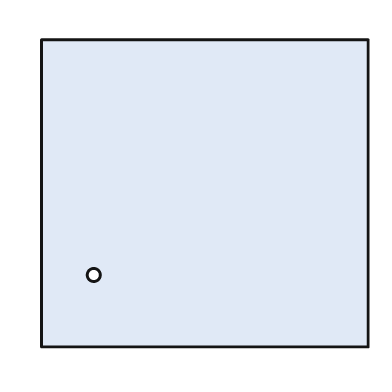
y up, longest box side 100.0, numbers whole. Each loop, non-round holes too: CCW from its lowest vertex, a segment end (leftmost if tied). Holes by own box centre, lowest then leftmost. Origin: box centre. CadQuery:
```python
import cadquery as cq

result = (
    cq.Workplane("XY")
    .moveTo(-50.0, -47.0)
    .lineTo(50.0, -47.0)
    .lineTo(50.0, 47.0)
    .lineTo(-50.0, 47.0)
    .close()
    .moveTo(-34.0, -25.0)
    .circle(2.0)
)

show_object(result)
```